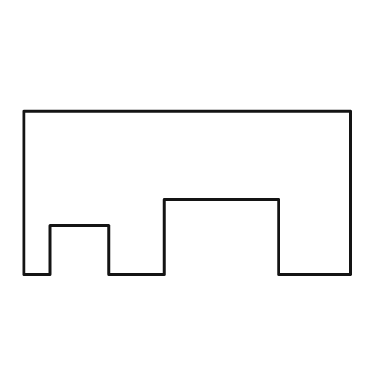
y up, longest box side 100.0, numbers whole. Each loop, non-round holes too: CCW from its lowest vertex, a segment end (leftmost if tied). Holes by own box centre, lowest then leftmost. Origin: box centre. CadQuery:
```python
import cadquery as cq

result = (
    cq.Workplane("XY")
    .moveTo(-50.0, -25.0)
    .lineTo(-42.0, -25.0)
    .lineTo(-42.0, -10.0)
    .lineTo(-24.0, -10.0)
    .lineTo(-24.0, -25.0)
    .lineTo(-7.0, -25.0)
    .lineTo(-7.0, -2.0)
    .lineTo(28.0, -2.0)
    .lineTo(28.0, -25.0)
    .lineTo(50.0, -25.0)
    .lineTo(50.0, 25.0)
    .lineTo(-50.0, 25.0)
    .close()
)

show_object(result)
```